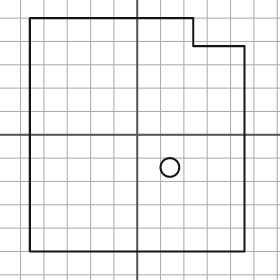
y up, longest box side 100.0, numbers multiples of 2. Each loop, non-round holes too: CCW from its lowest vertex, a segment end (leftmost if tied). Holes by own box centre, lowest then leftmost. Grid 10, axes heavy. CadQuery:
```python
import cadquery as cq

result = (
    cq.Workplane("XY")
    .moveTo(-46.0, -50.0)
    .lineTo(46.0, -50.0)
    .lineTo(46.0, 38.0)
    .lineTo(24.0, 38.0)
    .lineTo(24.0, 50.0)
    .lineTo(-46.0, 50.0)
    .close()
    .moveTo(14.0, -14.0)
    .circle(4.0)
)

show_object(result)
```